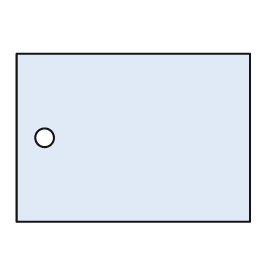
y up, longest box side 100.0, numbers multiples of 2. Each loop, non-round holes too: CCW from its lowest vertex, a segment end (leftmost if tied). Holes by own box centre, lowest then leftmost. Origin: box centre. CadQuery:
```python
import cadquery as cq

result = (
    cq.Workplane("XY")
    .moveTo(-50.0, -36.0)
    .lineTo(50.0, -36.0)
    .lineTo(50.0, 36.0)
    .lineTo(-50.0, 36.0)
    .close()
    .moveTo(-38.0, 0.0)
    .circle(4.0)
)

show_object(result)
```